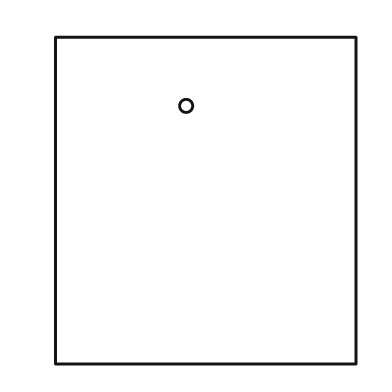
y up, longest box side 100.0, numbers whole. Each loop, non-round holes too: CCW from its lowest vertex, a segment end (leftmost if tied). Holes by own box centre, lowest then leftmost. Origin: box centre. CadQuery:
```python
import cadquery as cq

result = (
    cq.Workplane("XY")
    .moveTo(-46.0, -50.0)
    .lineTo(46.0, -50.0)
    .lineTo(46.0, 50.0)
    .lineTo(-46.0, 50.0)
    .close()
    .moveTo(-6.0, 29.0)
    .circle(2.0)
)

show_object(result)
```